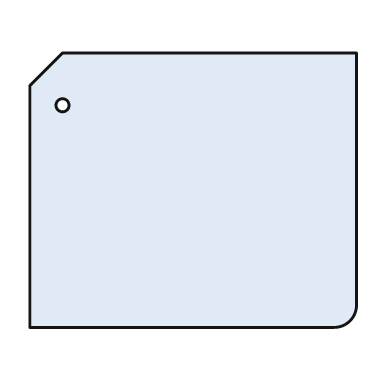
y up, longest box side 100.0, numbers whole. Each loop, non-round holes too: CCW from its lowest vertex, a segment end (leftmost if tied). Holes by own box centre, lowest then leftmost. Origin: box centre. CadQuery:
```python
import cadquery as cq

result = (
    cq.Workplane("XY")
    .moveTo(-50.0, -42.0)
    .lineTo(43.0, -42.0)
    .threePointArc((48.0, -40.0), (50.0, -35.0))
    .lineTo(50.0, 42.0)
    .lineTo(-40.0, 42.0)
    .lineTo(-50.0, 32.0)
    .close()
    .moveTo(-40.0, 26.0)
    .circle(2.0)
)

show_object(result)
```